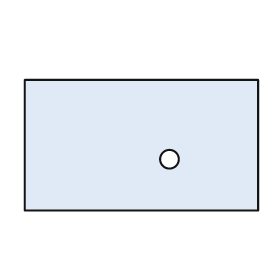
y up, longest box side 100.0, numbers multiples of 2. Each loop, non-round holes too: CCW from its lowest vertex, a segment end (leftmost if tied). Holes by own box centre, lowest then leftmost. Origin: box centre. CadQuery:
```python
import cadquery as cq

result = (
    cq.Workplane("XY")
    .moveTo(-50.0, -28.0)
    .lineTo(50.0, -28.0)
    .lineTo(50.0, 28.0)
    .lineTo(-50.0, 28.0)
    .close()
    .moveTo(12.0, -6.0)
    .circle(4.0)
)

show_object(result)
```